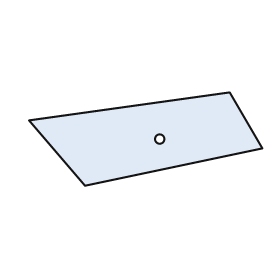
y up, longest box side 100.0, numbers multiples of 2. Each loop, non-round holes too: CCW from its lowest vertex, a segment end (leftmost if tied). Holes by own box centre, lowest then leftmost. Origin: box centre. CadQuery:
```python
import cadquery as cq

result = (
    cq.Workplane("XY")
    .moveTo(-26.0, -20.0)
    .lineTo(50.0, -4.0)
    .lineTo(36.0, 20.0)
    .lineTo(-50.0, 8.0)
    .close()
    .moveTo(6.0, 0.0)
    .circle(2.0)
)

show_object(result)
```